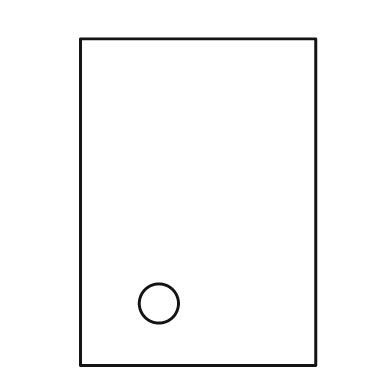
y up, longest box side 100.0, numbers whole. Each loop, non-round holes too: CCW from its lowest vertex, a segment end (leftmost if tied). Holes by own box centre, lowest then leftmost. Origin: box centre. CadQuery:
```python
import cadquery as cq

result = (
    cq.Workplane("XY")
    .moveTo(-36.0, -50.0)
    .lineTo(36.0, -50.0)
    .lineTo(36.0, 50.0)
    .lineTo(-36.0, 50.0)
    .close()
    .moveTo(-12.0, -31.0)
    .circle(6.0)
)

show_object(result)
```